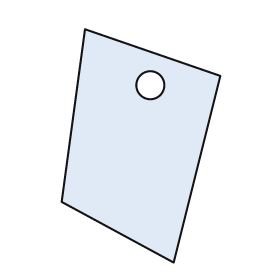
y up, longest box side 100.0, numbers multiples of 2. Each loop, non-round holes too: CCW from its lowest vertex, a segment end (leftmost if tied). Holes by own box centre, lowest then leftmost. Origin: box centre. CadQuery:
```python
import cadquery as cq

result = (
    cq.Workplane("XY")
    .moveTo(14.0, -50.0)
    .lineTo(34.0, 30.0)
    .lineTo(-24.0, 50.0)
    .lineTo(-34.0, -24.0)
    .close()
    .moveTo(4.0, 26.0)
    .circle(6.0)
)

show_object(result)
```